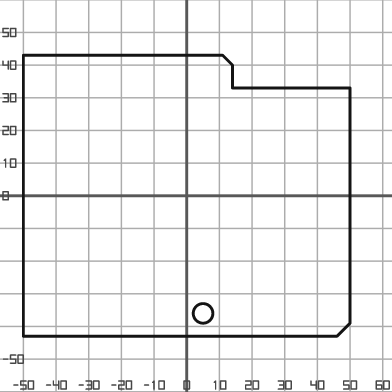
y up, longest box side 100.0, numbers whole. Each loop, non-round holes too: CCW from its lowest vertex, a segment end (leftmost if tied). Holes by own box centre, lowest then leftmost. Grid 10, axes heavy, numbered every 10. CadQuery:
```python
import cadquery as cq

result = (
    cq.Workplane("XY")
    .moveTo(-50.0, -43.0)
    .lineTo(46.0, -43.0)
    .lineTo(50.0, -39.0)
    .lineTo(50.0, 33.0)
    .lineTo(14.0, 33.0)
    .lineTo(14.0, 40.0)
    .lineTo(11.0, 43.0)
    .lineTo(-50.0, 43.0)
    .close()
    .moveTo(5.0, -36.0)
    .circle(3.0)
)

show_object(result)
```